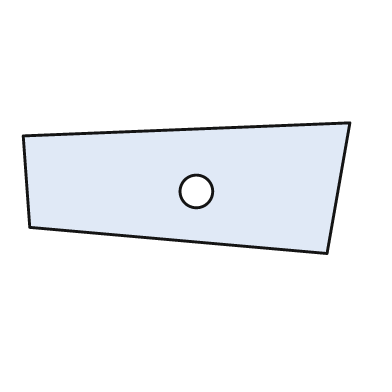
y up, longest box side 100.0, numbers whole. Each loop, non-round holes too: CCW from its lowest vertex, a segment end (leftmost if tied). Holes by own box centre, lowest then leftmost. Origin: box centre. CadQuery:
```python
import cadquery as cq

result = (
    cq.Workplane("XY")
    .moveTo(43.0, -20.0)
    .lineTo(50.0, 20.0)
    .lineTo(-50.0, 16.0)
    .lineTo(-48.0, -12.0)
    .close()
    .moveTo(3.0, -1.0)
    .circle(5.0)
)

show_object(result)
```